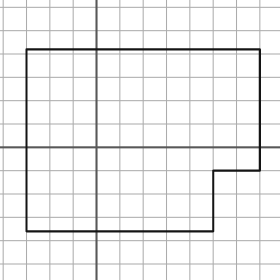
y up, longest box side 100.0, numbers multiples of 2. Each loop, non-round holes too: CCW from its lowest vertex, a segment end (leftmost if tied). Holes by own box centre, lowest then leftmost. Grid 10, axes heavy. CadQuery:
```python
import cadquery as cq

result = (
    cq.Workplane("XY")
    .moveTo(-30.0, -36.0)
    .lineTo(50.0, -36.0)
    .lineTo(50.0, -10.0)
    .lineTo(70.0, -10.0)
    .lineTo(70.0, 42.0)
    .lineTo(-30.0, 42.0)
    .close()
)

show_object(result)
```